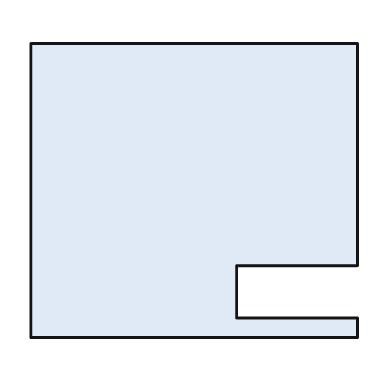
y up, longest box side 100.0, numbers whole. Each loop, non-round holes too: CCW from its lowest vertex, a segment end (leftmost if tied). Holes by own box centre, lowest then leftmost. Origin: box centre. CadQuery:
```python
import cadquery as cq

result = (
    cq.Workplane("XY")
    .moveTo(-50.0, -45.0)
    .lineTo(50.0, -45.0)
    .lineTo(50.0, -39.0)
    .lineTo(13.0, -39.0)
    .lineTo(13.0, -23.0)
    .lineTo(50.0, -23.0)
    .lineTo(50.0, 45.0)
    .lineTo(-50.0, 45.0)
    .close()
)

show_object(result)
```